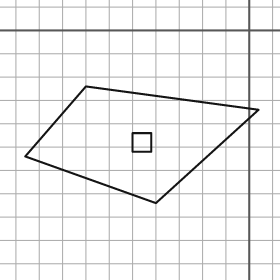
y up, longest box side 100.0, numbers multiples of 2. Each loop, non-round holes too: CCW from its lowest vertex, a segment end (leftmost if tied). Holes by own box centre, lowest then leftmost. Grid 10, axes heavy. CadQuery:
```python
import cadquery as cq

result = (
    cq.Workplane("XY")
    .moveTo(-40.0, -74.0)
    .lineTo(4.0, -34.0)
    .lineTo(-70.0, -24.0)
    .lineTo(-96.0, -54.0)
    .close()
    .moveTo(-50.0, -52.0)
    .lineTo(-42.0, -52.0)
    .lineTo(-42.0, -44.0)
    .lineTo(-50.0, -44.0)
    .close()
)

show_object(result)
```